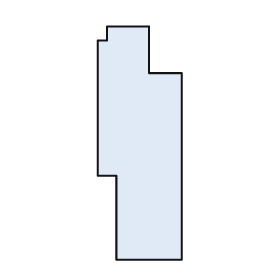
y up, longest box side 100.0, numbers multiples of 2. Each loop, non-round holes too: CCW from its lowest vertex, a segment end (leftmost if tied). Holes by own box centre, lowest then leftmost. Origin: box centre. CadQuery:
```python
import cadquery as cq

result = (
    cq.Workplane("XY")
    .moveTo(-10.0, -50.0)
    .lineTo(18.0, -50.0)
    .lineTo(18.0, 30.0)
    .lineTo(4.0, 30.0)
    .lineTo(4.0, 50.0)
    .lineTo(-14.0, 50.0)
    .lineTo(-14.0, 44.0)
    .lineTo(-18.0, 44.0)
    .lineTo(-18.0, -14.0)
    .lineTo(-10.0, -14.0)
    .close()
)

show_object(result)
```